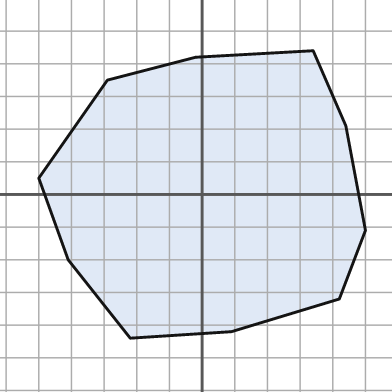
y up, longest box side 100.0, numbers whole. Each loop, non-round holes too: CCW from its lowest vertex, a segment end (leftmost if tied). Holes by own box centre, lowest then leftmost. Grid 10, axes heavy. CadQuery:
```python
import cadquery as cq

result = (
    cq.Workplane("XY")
    .moveTo(-22.0, -44.0)
    .lineTo(9.0, -42.0)
    .lineTo(42.0, -32.0)
    .lineTo(50.0, -11.0)
    .lineTo(44.0, 21.0)
    .lineTo(34.0, 44.0)
    .lineTo(-2.0, 42.0)
    .lineTo(-29.0, 35.0)
    .lineTo(-50.0, 5.0)
    .lineTo(-41.0, -20.0)
    .close()
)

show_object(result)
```